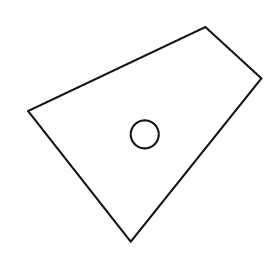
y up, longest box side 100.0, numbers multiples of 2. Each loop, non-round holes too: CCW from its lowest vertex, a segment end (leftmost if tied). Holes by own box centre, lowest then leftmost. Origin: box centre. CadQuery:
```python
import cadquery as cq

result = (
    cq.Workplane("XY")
    .moveTo(-6.0, -46.0)
    .lineTo(50.0, 24.0)
    .lineTo(26.0, 46.0)
    .lineTo(-50.0, 10.0)
    .close()
    .moveTo(0.0, 0.0)
    .circle(6.0)
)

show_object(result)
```